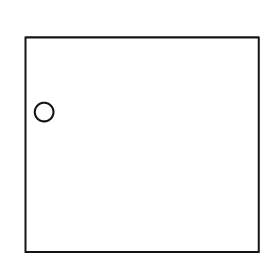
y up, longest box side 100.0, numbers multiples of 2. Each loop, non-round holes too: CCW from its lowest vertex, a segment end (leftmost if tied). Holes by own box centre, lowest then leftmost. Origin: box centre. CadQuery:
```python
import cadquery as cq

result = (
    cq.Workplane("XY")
    .moveTo(-50.0, -46.0)
    .lineTo(50.0, -46.0)
    .lineTo(50.0, 46.0)
    .lineTo(-50.0, 46.0)
    .close()
    .moveTo(-42.0, 14.0)
    .circle(4.0)
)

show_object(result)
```